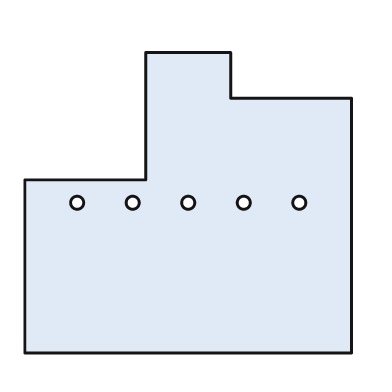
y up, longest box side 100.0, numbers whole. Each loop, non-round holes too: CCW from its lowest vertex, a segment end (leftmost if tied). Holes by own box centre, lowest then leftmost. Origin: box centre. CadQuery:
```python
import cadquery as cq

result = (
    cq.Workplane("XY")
    .moveTo(-50.0, -46.0)
    .lineTo(50.0, -46.0)
    .lineTo(50.0, 32.0)
    .lineTo(13.0, 32.0)
    .lineTo(13.0, 46.0)
    .lineTo(-13.0, 46.0)
    .lineTo(-13.0, 7.0)
    .lineTo(-50.0, 7.0)
    .close()
    .moveTo(-34.0, 0.0)
    .circle(2.0)
    .moveTo(-17.0, 0.0)
    .circle(2.0)
    .moveTo(0.0, 0.0)
    .circle(2.0)
    .moveTo(17.0, 0.0)
    .circle(2.0)
    .moveTo(34.0, 0.0)
    .circle(2.0)
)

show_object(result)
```